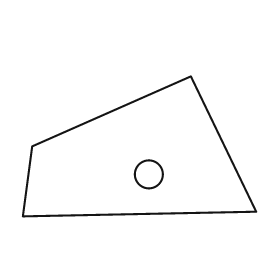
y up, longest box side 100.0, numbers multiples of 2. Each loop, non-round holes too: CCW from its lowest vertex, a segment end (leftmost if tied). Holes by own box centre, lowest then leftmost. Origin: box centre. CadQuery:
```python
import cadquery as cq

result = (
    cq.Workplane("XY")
    .moveTo(-50.0, -30.0)
    .lineTo(50.0, -28.0)
    .lineTo(22.0, 30.0)
    .lineTo(-46.0, 0.0)
    .close()
    .moveTo(4.0, -12.0)
    .circle(6.0)
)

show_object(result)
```